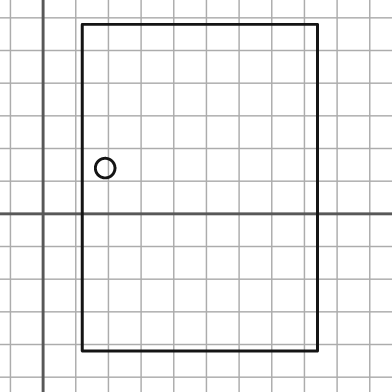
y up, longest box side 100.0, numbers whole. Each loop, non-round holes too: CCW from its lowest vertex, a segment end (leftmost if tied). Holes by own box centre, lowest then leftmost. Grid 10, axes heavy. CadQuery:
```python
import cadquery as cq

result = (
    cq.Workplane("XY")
    .moveTo(12.0, -42.0)
    .lineTo(84.0, -42.0)
    .lineTo(84.0, 58.0)
    .lineTo(12.0, 58.0)
    .close()
    .moveTo(19.0, 14.0)
    .circle(3.0)
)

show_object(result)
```